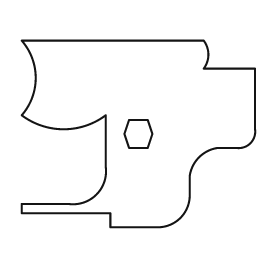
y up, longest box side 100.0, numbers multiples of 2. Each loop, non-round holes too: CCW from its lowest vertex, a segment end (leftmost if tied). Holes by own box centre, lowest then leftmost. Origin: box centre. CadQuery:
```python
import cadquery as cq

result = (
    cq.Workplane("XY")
    .moveTo(-12.0, -40.0)
    .lineTo(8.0, -40.0)
    .threePointArc((18.0, -36.0), (22.0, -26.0))
    .lineTo(22.0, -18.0)
    .threePointArc((26.0, -10.0), (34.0, -6.0))
    .lineTo(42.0, -6.0)
    .threePointArc((48.0, -4.0), (50.0, 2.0))
    .lineTo(50.0, 28.0)
    .lineTo(28.0, 28.0)
    .threePointArc((30.0, 34.0), (28.0, 40.0))
    .lineTo(-50.0, 40.0)
    .threePointArc((-44.0, 24.0), (-50.0, 8.0))
    .threePointArc((-32.0, 2.0), (-14.0, 8.0))
    .lineTo(-14.0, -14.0)
    .threePointArc((-18.0, -26.0), (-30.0, -30.0))
    .lineTo(-50.0, -30.0)
    .lineTo(-50.0, -34.0)
    .lineTo(-12.0, -34.0)
    .close()
    .moveTo(-4.0, -6.0)
    .lineTo(4.0, -6.0)
    .lineTo(6.0, 0.0)
    .lineTo(4.0, 6.0)
    .lineTo(-4.0, 6.0)
    .lineTo(-6.0, 0.0)
    .close()
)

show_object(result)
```